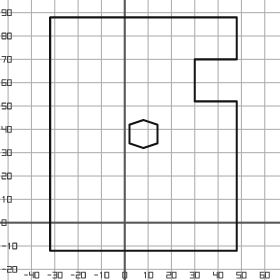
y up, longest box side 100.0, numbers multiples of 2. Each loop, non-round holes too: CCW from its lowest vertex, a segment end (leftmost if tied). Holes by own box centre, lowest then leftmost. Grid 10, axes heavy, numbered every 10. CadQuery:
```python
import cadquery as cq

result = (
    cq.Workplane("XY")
    .moveTo(-32.0, -12.0)
    .lineTo(48.0, -12.0)
    .lineTo(48.0, 52.0)
    .lineTo(30.0, 52.0)
    .lineTo(30.0, 70.0)
    .lineTo(48.0, 70.0)
    .lineTo(48.0, 88.0)
    .lineTo(-32.0, 88.0)
    .close()
    .moveTo(8.0, 32.0)
    .lineTo(14.0, 34.0)
    .lineTo(14.0, 42.0)
    .lineTo(8.0, 44.0)
    .lineTo(2.0, 42.0)
    .lineTo(2.0, 34.0)
    .close()
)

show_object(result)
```